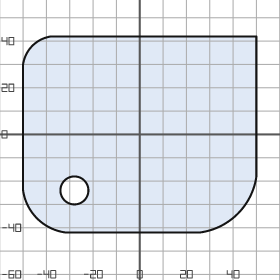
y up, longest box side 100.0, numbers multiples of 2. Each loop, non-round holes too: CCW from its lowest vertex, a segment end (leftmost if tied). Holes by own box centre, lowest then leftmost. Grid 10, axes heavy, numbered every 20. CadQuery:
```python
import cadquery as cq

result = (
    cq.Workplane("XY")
    .moveTo(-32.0, -42.0)
    .lineTo(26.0, -42.0)
    .threePointArc((42.0, -34.0), (50.0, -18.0))
    .lineTo(50.0, 42.0)
    .lineTo(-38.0, 42.0)
    .threePointArc((-46.0, 38.0), (-50.0, 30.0))
    .lineTo(-50.0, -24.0)
    .threePointArc((-44.0, -36.0), (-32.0, -42.0))
    .close()
    .moveTo(-28.0, -24.0)
    .circle(6.0)
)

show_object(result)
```